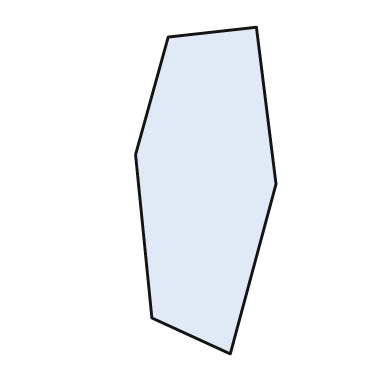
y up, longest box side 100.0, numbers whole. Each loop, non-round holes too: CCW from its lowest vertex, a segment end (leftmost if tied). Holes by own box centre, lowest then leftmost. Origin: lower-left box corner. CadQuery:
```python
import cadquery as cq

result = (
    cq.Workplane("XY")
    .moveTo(29.0, 0.0)
    .lineTo(43.0, 52.0)
    .lineTo(37.0, 100.0)
    .lineTo(10.0, 97.0)
    .lineTo(0.0, 61.0)
    .lineTo(5.0, 11.0)
    .close()
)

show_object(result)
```